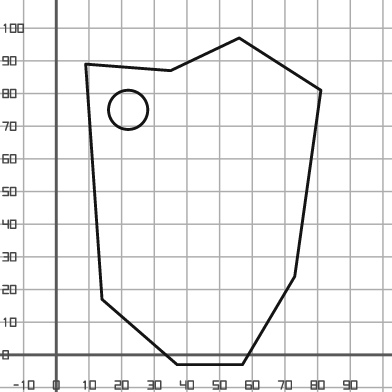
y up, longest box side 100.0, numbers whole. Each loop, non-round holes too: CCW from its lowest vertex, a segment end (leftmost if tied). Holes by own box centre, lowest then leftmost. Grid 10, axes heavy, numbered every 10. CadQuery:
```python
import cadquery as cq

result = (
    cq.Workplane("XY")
    .moveTo(37.0, -3.0)
    .lineTo(57.0, -3.0)
    .lineTo(73.0, 24.0)
    .lineTo(81.0, 81.0)
    .lineTo(56.0, 97.0)
    .lineTo(35.0, 87.0)
    .lineTo(9.0, 89.0)
    .lineTo(14.0, 17.0)
    .close()
    .moveTo(22.0, 75.0)
    .circle(6.0)
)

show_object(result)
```